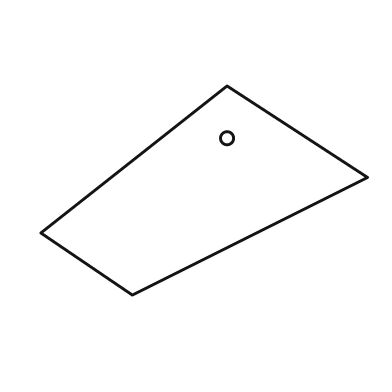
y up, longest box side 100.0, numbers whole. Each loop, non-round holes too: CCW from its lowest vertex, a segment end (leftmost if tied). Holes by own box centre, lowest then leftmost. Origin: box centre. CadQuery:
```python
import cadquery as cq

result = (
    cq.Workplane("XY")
    .moveTo(-22.0, -32.0)
    .lineTo(50.0, 4.0)
    .lineTo(7.0, 32.0)
    .lineTo(-50.0, -13.0)
    .close()
    .moveTo(7.0, 16.0)
    .circle(2.0)
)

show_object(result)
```